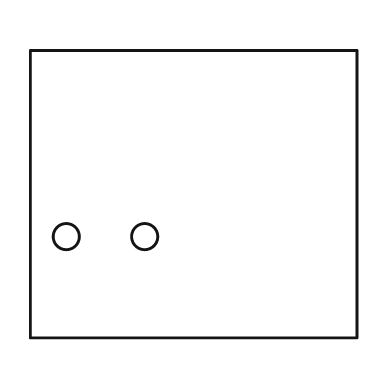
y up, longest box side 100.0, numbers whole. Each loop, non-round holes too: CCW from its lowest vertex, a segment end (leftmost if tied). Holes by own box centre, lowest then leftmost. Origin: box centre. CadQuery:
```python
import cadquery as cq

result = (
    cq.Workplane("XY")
    .moveTo(-50.0, -44.0)
    .lineTo(50.0, -44.0)
    .lineTo(50.0, 44.0)
    .lineTo(-50.0, 44.0)
    .close()
    .moveTo(-39.0, -13.0)
    .circle(4.0)
    .moveTo(-15.0, -13.0)
    .circle(4.0)
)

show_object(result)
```